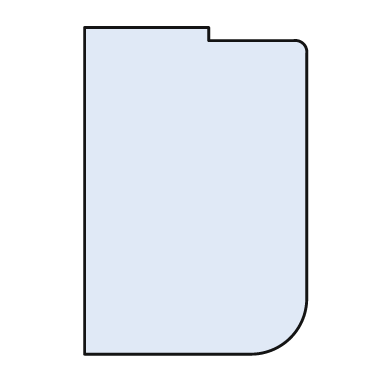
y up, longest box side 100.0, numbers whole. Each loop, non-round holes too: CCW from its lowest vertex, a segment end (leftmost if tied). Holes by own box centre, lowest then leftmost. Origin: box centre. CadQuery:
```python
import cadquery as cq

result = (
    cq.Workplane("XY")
    .moveTo(-34.0, -50.0)
    .lineTo(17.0, -50.0)
    .threePointArc((29.0, -45.0), (34.0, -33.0))
    .lineTo(34.0, 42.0)
    .threePointArc((33.0, 45.0), (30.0, 46.0))
    .lineTo(4.0, 46.0)
    .lineTo(4.0, 50.0)
    .lineTo(-34.0, 50.0)
    .close()
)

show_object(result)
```